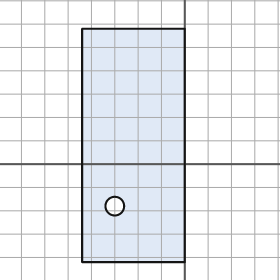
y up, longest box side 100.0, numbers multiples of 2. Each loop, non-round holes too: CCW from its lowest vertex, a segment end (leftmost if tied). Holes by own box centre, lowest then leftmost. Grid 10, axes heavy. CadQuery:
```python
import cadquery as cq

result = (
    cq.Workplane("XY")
    .moveTo(-44.0, -42.0)
    .lineTo(0.0, -42.0)
    .lineTo(0.0, 58.0)
    .lineTo(-44.0, 58.0)
    .close()
    .moveTo(-30.0, -18.0)
    .circle(4.0)
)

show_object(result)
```